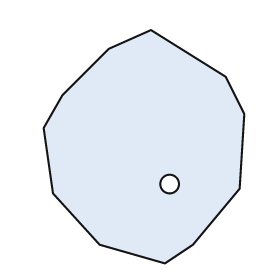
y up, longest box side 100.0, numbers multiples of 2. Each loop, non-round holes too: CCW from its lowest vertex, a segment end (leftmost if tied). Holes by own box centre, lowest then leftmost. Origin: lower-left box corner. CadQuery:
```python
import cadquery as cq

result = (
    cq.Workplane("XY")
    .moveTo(52.0, 0.0)
    .lineTo(64.0, 8.0)
    .lineTo(84.0, 32.0)
    .lineTo(86.0, 64.0)
    .lineTo(78.0, 80.0)
    .lineTo(46.0, 100.0)
    .lineTo(28.0, 92.0)
    .lineTo(8.0, 72.0)
    .lineTo(0.0, 58.0)
    .lineTo(4.0, 30.0)
    .lineTo(24.0, 8.0)
    .close()
    .moveTo(54.0, 34.0)
    .circle(4.0)
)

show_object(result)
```